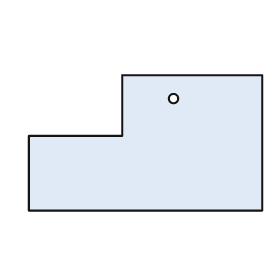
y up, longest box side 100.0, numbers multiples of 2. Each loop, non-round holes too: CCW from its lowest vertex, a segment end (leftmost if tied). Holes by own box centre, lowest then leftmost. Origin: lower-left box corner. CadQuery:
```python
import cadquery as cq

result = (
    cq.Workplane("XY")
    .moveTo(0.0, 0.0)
    .lineTo(100.0, 0.0)
    .lineTo(100.0, 58.0)
    .lineTo(40.0, 58.0)
    .lineTo(40.0, 32.0)
    .lineTo(0.0, 32.0)
    .close()
    .moveTo(62.0, 48.0)
    .circle(2.0)
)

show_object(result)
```